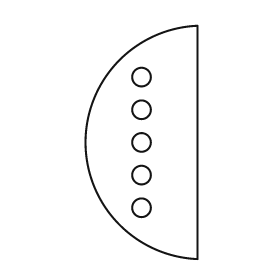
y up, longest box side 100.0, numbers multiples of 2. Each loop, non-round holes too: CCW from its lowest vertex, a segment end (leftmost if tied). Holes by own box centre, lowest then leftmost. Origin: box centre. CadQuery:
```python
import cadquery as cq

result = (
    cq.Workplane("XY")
    .moveTo(24.0, -50.0)
    .lineTo(24.0, 50.0)
    .threePointArc((-24.0, 0.0), (24.0, -50.0))
    .close()
    .moveTo(0.0, -28.0)
    .circle(4.0)
    .moveTo(0.0, -14.0)
    .circle(4.0)
    .moveTo(0.0, 0.0)
    .circle(4.0)
    .moveTo(0.0, 14.0)
    .circle(4.0)
    .moveTo(0.0, 28.0)
    .circle(4.0)
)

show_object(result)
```